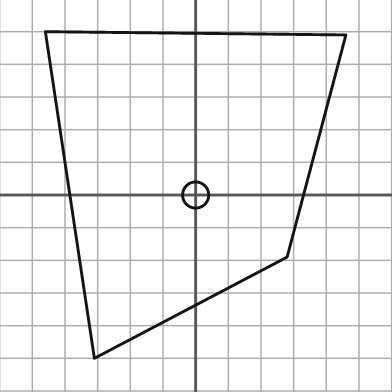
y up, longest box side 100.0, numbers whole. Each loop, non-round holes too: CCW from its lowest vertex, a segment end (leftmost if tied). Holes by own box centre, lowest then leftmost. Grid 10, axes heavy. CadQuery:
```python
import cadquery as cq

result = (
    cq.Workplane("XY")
    .moveTo(-31.0, -50.0)
    .lineTo(28.0, -19.0)
    .lineTo(46.0, 49.0)
    .lineTo(-46.0, 50.0)
    .close()
    .moveTo(0.0, 0.0)
    .circle(4.0)
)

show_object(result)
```